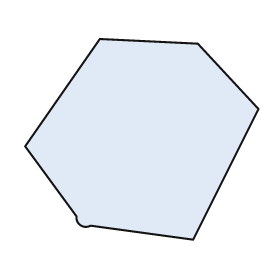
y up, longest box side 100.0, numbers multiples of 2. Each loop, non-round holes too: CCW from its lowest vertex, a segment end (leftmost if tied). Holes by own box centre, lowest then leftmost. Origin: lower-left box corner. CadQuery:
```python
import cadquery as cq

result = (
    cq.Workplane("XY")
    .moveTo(72.0, 0.0)
    .lineTo(100.0, 56.0)
    .lineTo(74.0, 84.0)
    .lineTo(32.0, 86.0)
    .lineTo(0.0, 40.0)
    .lineTo(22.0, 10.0)
    .threePointArc((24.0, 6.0), (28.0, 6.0))
    .close()
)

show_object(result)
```